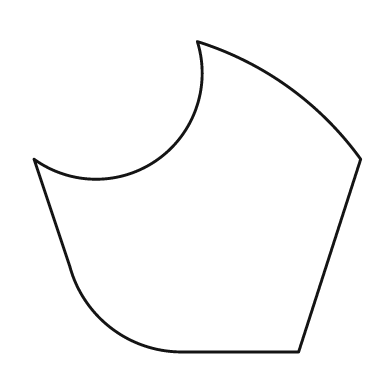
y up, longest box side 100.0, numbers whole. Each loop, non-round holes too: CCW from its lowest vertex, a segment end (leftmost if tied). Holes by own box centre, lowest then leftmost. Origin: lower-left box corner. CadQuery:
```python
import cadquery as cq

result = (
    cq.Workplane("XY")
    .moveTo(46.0, 0.0)
    .lineTo(81.0, 0.0)
    .lineTo(100.0, 59.0)
    .threePointArc((78.0, 81.0), (50.0, 95.0))
    .threePointArc((38.0, 59.0), (0.0, 59.0))
    .lineTo(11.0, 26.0)
    .threePointArc((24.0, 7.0), (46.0, 0.0))
    .close()
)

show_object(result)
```